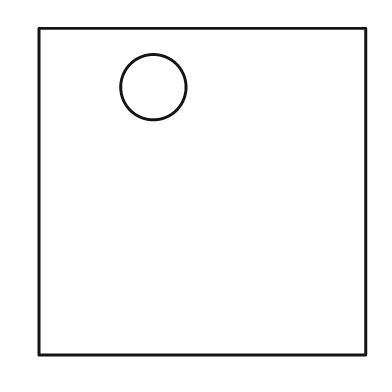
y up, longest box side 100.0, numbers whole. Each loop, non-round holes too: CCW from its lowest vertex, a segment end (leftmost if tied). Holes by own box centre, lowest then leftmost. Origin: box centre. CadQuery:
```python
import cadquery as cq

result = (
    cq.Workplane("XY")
    .moveTo(-50.0, -50.0)
    .lineTo(50.0, -50.0)
    .lineTo(50.0, 50.0)
    .lineTo(-50.0, 50.0)
    .close()
    .moveTo(-15.0, 32.0)
    .circle(10.0)
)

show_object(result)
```